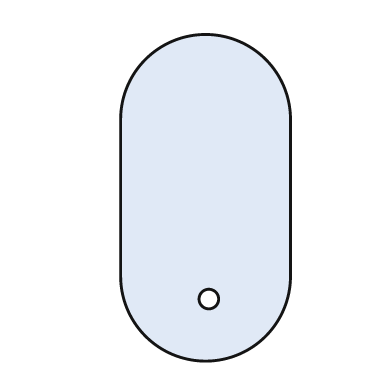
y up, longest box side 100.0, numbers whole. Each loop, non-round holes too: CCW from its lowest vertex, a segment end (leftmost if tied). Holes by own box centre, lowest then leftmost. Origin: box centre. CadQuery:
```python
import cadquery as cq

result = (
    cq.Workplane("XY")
    .moveTo(-26.0, -24.0)
    .threePointArc((0.0, -50.0), (26.0, -24.0))
    .lineTo(26.0, 24.0)
    .threePointArc((0.0, 50.0), (-26.0, 24.0))
    .close()
    .moveTo(1.0, -31.0)
    .circle(3.0)
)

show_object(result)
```